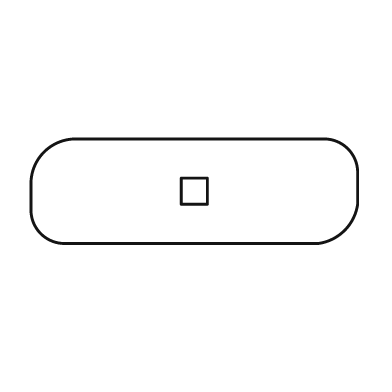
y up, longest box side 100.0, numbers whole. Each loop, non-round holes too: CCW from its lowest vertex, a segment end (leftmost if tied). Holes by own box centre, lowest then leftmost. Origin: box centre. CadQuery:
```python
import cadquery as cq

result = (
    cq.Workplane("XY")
    .moveTo(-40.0, -16.0)
    .lineTo(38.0, -16.0)
    .threePointArc((46.0, -12.0), (50.0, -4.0))
    .lineTo(50.0, 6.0)
    .threePointArc((47.0, 13.0), (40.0, 16.0))
    .lineTo(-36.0, 16.0)
    .threePointArc((-46.0, 12.0), (-50.0, 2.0))
    .lineTo(-50.0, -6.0)
    .threePointArc((-47.0, -13.0), (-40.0, -16.0))
    .close()
    .moveTo(-4.0, -4.0)
    .lineTo(4.0, -4.0)
    .lineTo(4.0, 4.0)
    .lineTo(-4.0, 4.0)
    .close()
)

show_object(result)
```